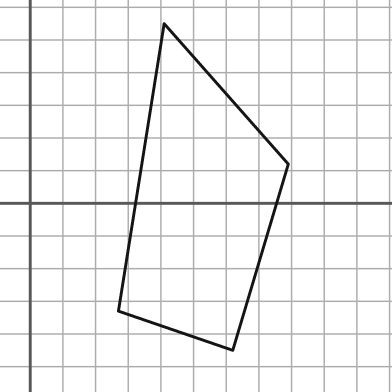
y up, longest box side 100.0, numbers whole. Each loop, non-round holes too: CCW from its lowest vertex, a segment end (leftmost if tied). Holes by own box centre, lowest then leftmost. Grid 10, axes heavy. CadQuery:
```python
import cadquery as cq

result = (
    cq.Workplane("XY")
    .moveTo(62.0, -45.0)
    .lineTo(79.0, 12.0)
    .lineTo(41.0, 55.0)
    .lineTo(27.0, -33.0)
    .close()
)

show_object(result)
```